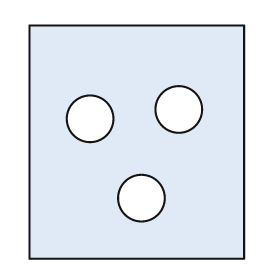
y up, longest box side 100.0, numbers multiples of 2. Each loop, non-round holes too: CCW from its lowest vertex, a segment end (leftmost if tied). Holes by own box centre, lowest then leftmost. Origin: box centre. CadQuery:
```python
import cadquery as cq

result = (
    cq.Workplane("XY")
    .moveTo(-46.0, -50.0)
    .lineTo(46.0, -50.0)
    .lineTo(46.0, 50.0)
    .lineTo(-46.0, 50.0)
    .close()
    .moveTo(2.0, -24.0)
    .circle(10.0)
    .moveTo(-20.0, 10.0)
    .circle(10.0)
    .moveTo(18.0, 14.0)
    .circle(10.0)
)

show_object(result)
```